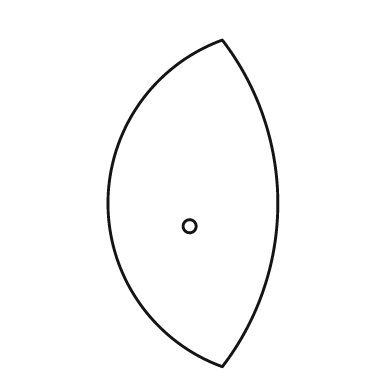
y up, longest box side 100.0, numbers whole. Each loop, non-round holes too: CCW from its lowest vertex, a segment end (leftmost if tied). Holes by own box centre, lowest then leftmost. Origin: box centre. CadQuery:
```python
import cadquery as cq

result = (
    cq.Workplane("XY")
    .moveTo(9.0, -50.0)
    .threePointArc((26.0, 0.0), (9.0, 50.0))
    .threePointArc((-26.0, 0.0), (9.0, -50.0))
    .close()
    .moveTo(-1.0, -7.0)
    .circle(2.0)
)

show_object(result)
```